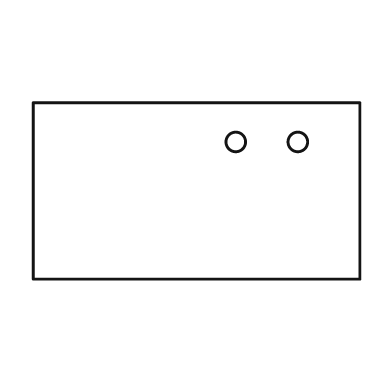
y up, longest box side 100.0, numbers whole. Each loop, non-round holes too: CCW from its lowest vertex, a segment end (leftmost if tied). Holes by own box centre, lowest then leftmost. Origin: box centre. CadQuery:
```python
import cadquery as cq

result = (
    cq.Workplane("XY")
    .moveTo(-50.0, -27.0)
    .lineTo(50.0, -27.0)
    .lineTo(50.0, 27.0)
    .lineTo(-50.0, 27.0)
    .close()
    .moveTo(12.0, 15.0)
    .circle(3.0)
    .moveTo(31.0, 15.0)
    .circle(3.0)
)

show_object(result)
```